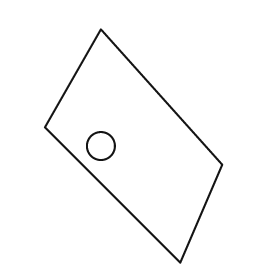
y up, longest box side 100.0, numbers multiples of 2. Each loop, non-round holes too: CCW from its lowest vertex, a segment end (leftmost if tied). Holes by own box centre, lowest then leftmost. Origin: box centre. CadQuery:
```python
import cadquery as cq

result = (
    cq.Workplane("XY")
    .moveTo(20.0, -50.0)
    .lineTo(38.0, -8.0)
    .lineTo(-14.0, 50.0)
    .lineTo(-38.0, 8.0)
    .close()
    .moveTo(-14.0, 0.0)
    .circle(6.0)
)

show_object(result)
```